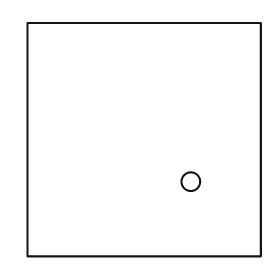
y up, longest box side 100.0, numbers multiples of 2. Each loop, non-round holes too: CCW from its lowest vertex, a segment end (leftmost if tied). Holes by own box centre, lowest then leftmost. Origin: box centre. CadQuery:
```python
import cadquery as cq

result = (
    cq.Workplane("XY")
    .moveTo(-50.0, -50.0)
    .lineTo(50.0, -50.0)
    .lineTo(50.0, 50.0)
    .lineTo(-50.0, 50.0)
    .close()
    .moveTo(20.0, -18.0)
    .circle(4.0)
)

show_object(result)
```